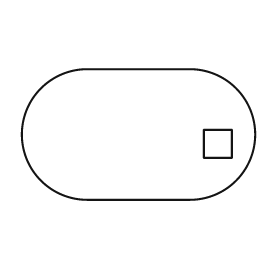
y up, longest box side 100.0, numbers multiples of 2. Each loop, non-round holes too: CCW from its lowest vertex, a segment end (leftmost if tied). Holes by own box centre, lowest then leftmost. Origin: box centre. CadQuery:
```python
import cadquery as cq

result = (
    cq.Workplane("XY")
    .moveTo(-22.0, -28.0)
    .lineTo(22.0, -28.0)
    .threePointArc((50.0, 0.0), (22.0, 28.0))
    .lineTo(-22.0, 28.0)
    .threePointArc((-50.0, 0.0), (-22.0, -28.0))
    .close()
    .moveTo(28.0, -10.0)
    .lineTo(40.0, -10.0)
    .lineTo(40.0, 2.0)
    .lineTo(28.0, 2.0)
    .close()
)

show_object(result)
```